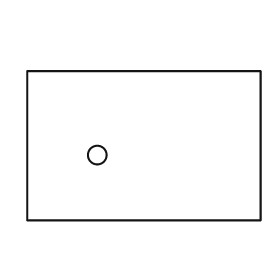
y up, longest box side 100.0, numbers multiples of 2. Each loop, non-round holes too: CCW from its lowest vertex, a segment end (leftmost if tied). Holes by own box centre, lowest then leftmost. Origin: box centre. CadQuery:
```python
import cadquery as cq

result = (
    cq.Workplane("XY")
    .moveTo(-50.0, -32.0)
    .lineTo(50.0, -32.0)
    .lineTo(50.0, 32.0)
    .lineTo(-50.0, 32.0)
    .close()
    .moveTo(-20.0, -4.0)
    .circle(4.0)
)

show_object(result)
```